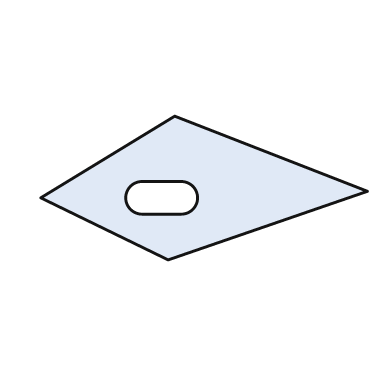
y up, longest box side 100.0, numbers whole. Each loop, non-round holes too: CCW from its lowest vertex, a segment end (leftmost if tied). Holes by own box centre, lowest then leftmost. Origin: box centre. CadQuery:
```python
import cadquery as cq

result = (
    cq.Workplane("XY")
    .moveTo(-11.0, -22.0)
    .lineTo(50.0, -1.0)
    .lineTo(-9.0, 22.0)
    .lineTo(-50.0, -3.0)
    .close()
    .moveTo(-19.0, -8.0)
    .lineTo(-7.0, -8.0)
    .threePointArc((-2.0, -3.0), (-7.0, 2.0))
    .lineTo(-19.0, 2.0)
    .threePointArc((-24.0, -3.0), (-19.0, -8.0))
    .close()
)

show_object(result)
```